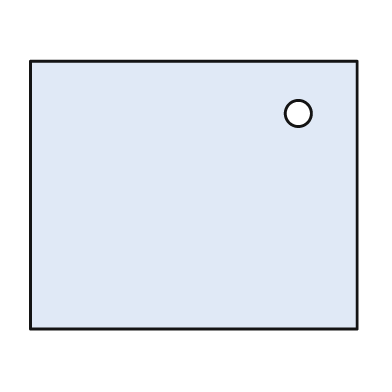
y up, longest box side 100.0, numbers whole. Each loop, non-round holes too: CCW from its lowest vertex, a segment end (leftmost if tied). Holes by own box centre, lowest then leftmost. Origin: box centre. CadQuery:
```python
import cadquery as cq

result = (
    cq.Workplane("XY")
    .moveTo(-50.0, -41.0)
    .lineTo(50.0, -41.0)
    .lineTo(50.0, 41.0)
    .lineTo(-50.0, 41.0)
    .close()
    .moveTo(32.0, 25.0)
    .circle(4.0)
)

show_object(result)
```